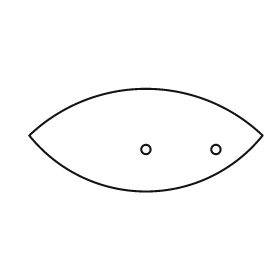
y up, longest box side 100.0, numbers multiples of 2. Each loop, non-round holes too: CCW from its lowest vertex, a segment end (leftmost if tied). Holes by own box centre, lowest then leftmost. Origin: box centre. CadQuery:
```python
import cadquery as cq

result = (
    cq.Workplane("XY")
    .moveTo(-50.0, 2.0)
    .threePointArc((0.0, -22.0), (50.0, 2.0))
    .threePointArc((0.0, 22.0), (-50.0, 2.0))
    .close()
    .moveTo(0.0, -4.0)
    .circle(2.0)
    .moveTo(30.0, -4.0)
    .circle(2.0)
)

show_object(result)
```